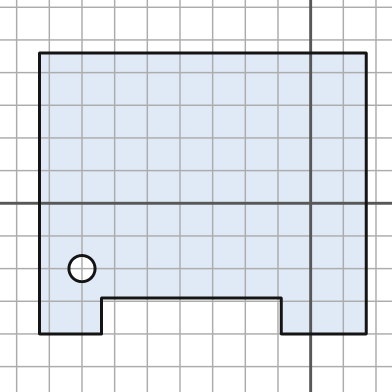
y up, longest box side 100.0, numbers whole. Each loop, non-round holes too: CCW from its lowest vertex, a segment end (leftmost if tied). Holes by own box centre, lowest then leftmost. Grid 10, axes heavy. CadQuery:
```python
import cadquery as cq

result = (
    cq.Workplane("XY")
    .moveTo(-83.0, -40.0)
    .lineTo(-64.0, -40.0)
    .lineTo(-64.0, -29.0)
    .lineTo(-9.0, -29.0)
    .lineTo(-9.0, -40.0)
    .lineTo(17.0, -40.0)
    .lineTo(17.0, 46.0)
    .lineTo(-83.0, 46.0)
    .close()
    .moveTo(-70.0, -20.0)
    .circle(4.0)
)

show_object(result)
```